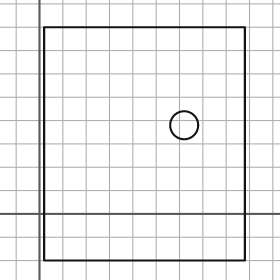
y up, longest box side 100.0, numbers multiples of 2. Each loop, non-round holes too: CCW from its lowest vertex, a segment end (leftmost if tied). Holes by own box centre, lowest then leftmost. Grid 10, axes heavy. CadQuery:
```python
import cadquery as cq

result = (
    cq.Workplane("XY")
    .moveTo(2.0, -20.0)
    .lineTo(88.0, -20.0)
    .lineTo(88.0, 80.0)
    .lineTo(2.0, 80.0)
    .close()
    .moveTo(62.0, 38.0)
    .circle(6.0)
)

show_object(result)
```